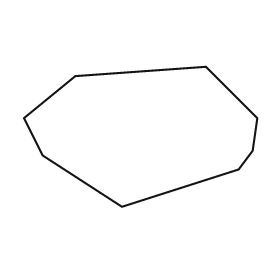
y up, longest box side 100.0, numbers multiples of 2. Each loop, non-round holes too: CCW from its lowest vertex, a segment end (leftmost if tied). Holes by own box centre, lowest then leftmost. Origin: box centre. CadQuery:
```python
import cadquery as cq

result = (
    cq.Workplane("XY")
    .moveTo(-8.0, -30.0)
    .lineTo(42.0, -14.0)
    .lineTo(48.0, -6.0)
    .lineTo(50.0, 8.0)
    .lineTo(28.0, 30.0)
    .lineTo(-28.0, 26.0)
    .lineTo(-50.0, 8.0)
    .lineTo(-42.0, -8.0)
    .close()
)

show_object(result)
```